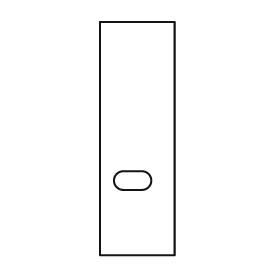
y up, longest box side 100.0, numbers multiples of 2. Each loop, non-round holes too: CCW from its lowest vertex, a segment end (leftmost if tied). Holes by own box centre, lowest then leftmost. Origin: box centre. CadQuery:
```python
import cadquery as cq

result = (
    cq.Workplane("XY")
    .moveTo(-16.0, -50.0)
    .lineTo(16.0, -50.0)
    .lineTo(16.0, 50.0)
    .lineTo(-16.0, 50.0)
    .close()
    .moveTo(-6.0, -22.0)
    .lineTo(2.0, -22.0)
    .threePointArc((6.0, -18.0), (2.0, -14.0))
    .lineTo(-6.0, -14.0)
    .threePointArc((-10.0, -18.0), (-6.0, -22.0))
    .close()
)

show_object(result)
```